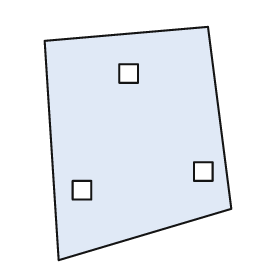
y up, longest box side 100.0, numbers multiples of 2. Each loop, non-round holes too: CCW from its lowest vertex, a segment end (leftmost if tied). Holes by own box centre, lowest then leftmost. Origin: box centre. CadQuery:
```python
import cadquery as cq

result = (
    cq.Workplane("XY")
    .moveTo(-34.0, -50.0)
    .lineTo(40.0, -28.0)
    .lineTo(30.0, 50.0)
    .lineTo(-40.0, 44.0)
    .close()
    .moveTo(-28.0, -24.0)
    .lineTo(-20.0, -24.0)
    .lineTo(-20.0, -16.0)
    .lineTo(-28.0, -16.0)
    .close()
    .moveTo(24.0, -16.0)
    .lineTo(32.0, -16.0)
    .lineTo(32.0, -8.0)
    .lineTo(24.0, -8.0)
    .close()
    .moveTo(-8.0, 26.0)
    .lineTo(0.0, 26.0)
    .lineTo(0.0, 34.0)
    .lineTo(-8.0, 34.0)
    .close()
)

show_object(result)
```